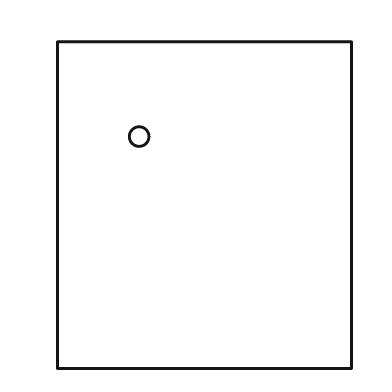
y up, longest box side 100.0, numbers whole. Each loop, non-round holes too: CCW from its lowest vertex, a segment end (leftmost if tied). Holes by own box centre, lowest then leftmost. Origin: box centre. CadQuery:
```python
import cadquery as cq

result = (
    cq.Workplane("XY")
    .moveTo(-45.0, -50.0)
    .lineTo(45.0, -50.0)
    .lineTo(45.0, 50.0)
    .lineTo(-45.0, 50.0)
    .close()
    .moveTo(-20.0, 21.0)
    .circle(3.0)
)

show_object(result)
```